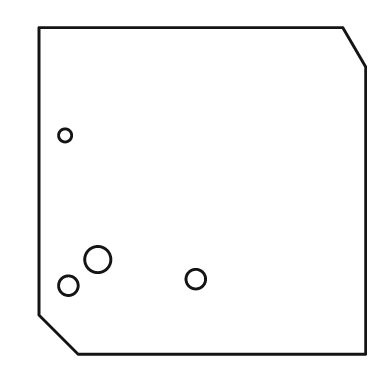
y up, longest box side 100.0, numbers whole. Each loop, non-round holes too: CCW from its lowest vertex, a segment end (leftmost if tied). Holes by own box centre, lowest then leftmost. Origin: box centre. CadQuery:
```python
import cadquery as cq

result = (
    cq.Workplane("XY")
    .moveTo(-38.0, -50.0)
    .lineTo(50.0, -50.0)
    .lineTo(50.0, 38.0)
    .lineTo(43.0, 50.0)
    .lineTo(-50.0, 50.0)
    .lineTo(-50.0, -38.0)
    .close()
    .moveTo(-41.0, -29.0)
    .circle(3.0)
    .moveTo(-2.0, -27.0)
    .circle(3.0)
    .moveTo(-32.0, -21.0)
    .circle(4.0)
    .moveTo(-42.0, 17.0)
    .circle(2.0)
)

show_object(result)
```